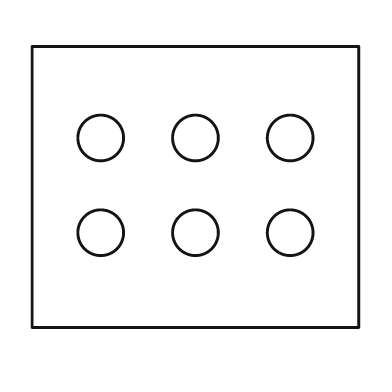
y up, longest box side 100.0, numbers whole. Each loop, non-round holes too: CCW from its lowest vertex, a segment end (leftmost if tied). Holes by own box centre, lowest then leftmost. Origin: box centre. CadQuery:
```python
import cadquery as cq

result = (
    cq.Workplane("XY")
    .moveTo(-50.0, -43.0)
    .lineTo(50.0, -43.0)
    .lineTo(50.0, 43.0)
    .lineTo(-50.0, 43.0)
    .close()
    .moveTo(-29.0, -14.0)
    .circle(7.0)
    .moveTo(0.0, -14.0)
    .circle(7.0)
    .moveTo(29.0, -14.0)
    .circle(7.0)
    .moveTo(-29.0, 15.0)
    .circle(7.0)
    .moveTo(0.0, 15.0)
    .circle(7.0)
    .moveTo(29.0, 15.0)
    .circle(7.0)
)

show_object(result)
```